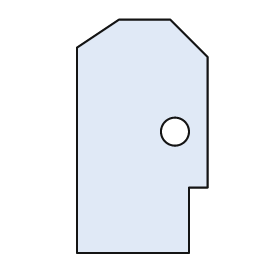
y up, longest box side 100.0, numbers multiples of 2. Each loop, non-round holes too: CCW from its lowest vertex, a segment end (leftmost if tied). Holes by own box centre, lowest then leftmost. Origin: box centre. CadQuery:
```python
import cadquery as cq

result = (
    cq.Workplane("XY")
    .moveTo(-28.0, -50.0)
    .lineTo(20.0, -50.0)
    .lineTo(20.0, -22.0)
    .lineTo(28.0, -22.0)
    .lineTo(28.0, 34.0)
    .lineTo(12.0, 50.0)
    .lineTo(-10.0, 50.0)
    .lineTo(-28.0, 38.0)
    .close()
    .moveTo(14.0, 2.0)
    .circle(6.0)
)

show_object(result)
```